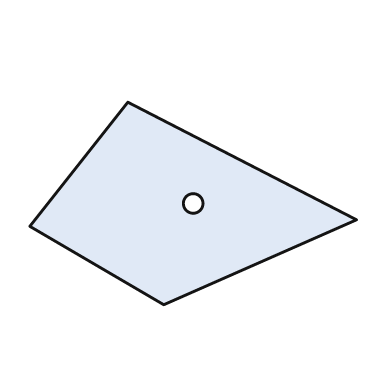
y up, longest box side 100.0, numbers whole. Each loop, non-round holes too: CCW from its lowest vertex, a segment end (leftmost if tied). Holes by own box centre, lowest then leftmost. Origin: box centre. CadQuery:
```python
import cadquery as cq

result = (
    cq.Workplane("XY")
    .moveTo(-9.0, -31.0)
    .lineTo(50.0, -5.0)
    .lineTo(-20.0, 31.0)
    .lineTo(-50.0, -7.0)
    .close()
    .moveTo(0.0, 0.0)
    .circle(3.0)
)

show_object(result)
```